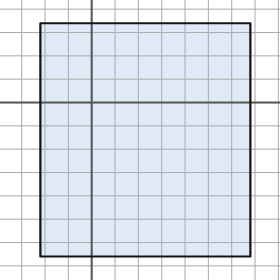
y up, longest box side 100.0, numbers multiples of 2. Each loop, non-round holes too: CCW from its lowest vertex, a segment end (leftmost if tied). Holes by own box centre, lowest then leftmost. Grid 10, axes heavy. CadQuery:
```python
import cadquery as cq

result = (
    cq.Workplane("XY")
    .moveTo(-22.0, -66.0)
    .lineTo(68.0, -66.0)
    .lineTo(68.0, 34.0)
    .lineTo(-22.0, 34.0)
    .close()
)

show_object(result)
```